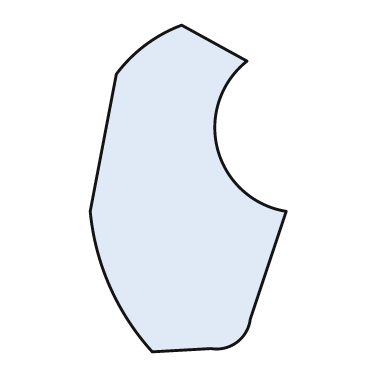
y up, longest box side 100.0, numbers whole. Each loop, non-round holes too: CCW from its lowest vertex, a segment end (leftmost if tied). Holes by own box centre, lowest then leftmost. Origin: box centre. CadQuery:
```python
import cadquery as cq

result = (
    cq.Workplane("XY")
    .moveTo(-11.0, -50.0)
    .lineTo(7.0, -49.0)
    .threePointArc((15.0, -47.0), (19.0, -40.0))
    .lineTo(30.0, -7.0)
    .threePointArc((9.0, 12.0), (18.0, 39.0))
    .lineTo(-2.0, 50.0)
    .threePointArc((-13.0, 44.0), (-22.0, 35.0))
    .lineTo(-30.0, -7.0)
    .threePointArc((-24.0, -30.0), (-11.0, -50.0))
    .close()
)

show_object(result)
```